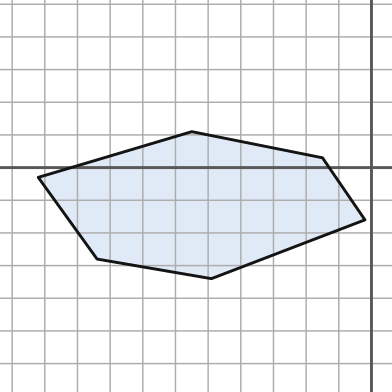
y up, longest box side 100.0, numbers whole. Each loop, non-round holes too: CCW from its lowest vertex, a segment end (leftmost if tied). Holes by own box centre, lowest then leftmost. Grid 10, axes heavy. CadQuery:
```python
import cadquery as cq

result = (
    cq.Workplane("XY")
    .moveTo(-49.0, -34.0)
    .lineTo(-2.0, -16.0)
    .lineTo(-15.0, 3.0)
    .lineTo(-55.0, 11.0)
    .lineTo(-102.0, -3.0)
    .lineTo(-84.0, -28.0)
    .close()
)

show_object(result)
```